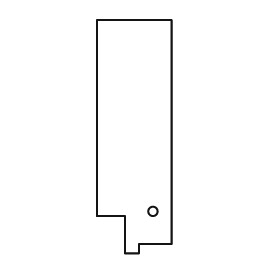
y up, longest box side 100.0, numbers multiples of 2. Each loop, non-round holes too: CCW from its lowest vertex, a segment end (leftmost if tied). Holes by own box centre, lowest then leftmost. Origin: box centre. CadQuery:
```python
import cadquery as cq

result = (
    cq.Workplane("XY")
    .moveTo(-4.0, -50.0)
    .lineTo(2.0, -50.0)
    .lineTo(2.0, -46.0)
    .lineTo(16.0, -46.0)
    .lineTo(16.0, 50.0)
    .lineTo(-16.0, 50.0)
    .lineTo(-16.0, -34.0)
    .lineTo(-4.0, -34.0)
    .close()
    .moveTo(8.0, -32.0)
    .circle(2.0)
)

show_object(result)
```